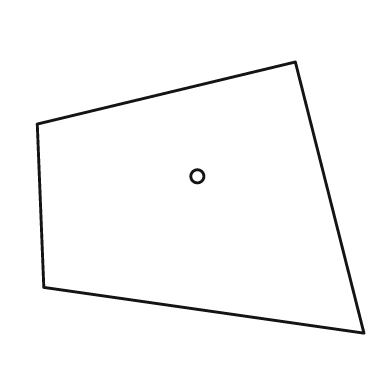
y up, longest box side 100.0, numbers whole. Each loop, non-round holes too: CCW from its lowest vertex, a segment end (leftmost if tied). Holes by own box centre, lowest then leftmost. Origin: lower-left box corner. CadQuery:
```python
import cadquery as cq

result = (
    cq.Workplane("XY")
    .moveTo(100.0, 0.0)
    .lineTo(79.0, 83.0)
    .lineTo(0.0, 64.0)
    .lineTo(2.0, 14.0)
    .close()
    .moveTo(49.0, 48.0)
    .circle(2.0)
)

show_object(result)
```